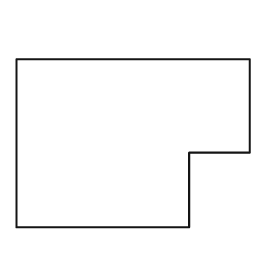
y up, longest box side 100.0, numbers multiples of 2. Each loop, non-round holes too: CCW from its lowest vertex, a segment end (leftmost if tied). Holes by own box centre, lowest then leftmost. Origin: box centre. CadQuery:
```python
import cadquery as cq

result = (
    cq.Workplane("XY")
    .moveTo(-50.0, -36.0)
    .lineTo(24.0, -36.0)
    .lineTo(24.0, -4.0)
    .lineTo(50.0, -4.0)
    .lineTo(50.0, 36.0)
    .lineTo(-50.0, 36.0)
    .close()
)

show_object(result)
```